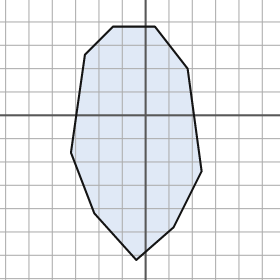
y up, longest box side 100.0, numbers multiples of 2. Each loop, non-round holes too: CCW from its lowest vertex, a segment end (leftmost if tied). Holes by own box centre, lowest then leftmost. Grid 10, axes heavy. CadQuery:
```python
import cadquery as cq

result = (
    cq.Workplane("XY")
    .moveTo(-4.0, -62.0)
    .lineTo(12.0, -48.0)
    .lineTo(24.0, -24.0)
    .lineTo(18.0, 20.0)
    .lineTo(4.0, 38.0)
    .lineTo(-14.0, 38.0)
    .lineTo(-26.0, 26.0)
    .lineTo(-32.0, -16.0)
    .lineTo(-22.0, -42.0)
    .close()
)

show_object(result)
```